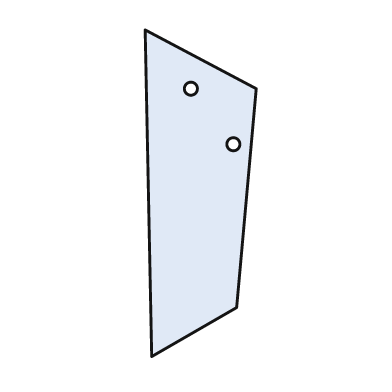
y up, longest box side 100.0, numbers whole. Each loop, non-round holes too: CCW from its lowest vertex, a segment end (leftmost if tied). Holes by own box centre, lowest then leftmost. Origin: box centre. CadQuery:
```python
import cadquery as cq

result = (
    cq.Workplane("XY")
    .moveTo(-15.0, -50.0)
    .lineTo(11.0, -35.0)
    .lineTo(17.0, 32.0)
    .lineTo(-17.0, 50.0)
    .close()
    .moveTo(10.0, 15.0)
    .circle(2.0)
    .moveTo(-3.0, 32.0)
    .circle(2.0)
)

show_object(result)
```